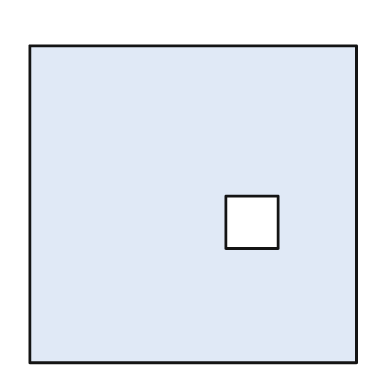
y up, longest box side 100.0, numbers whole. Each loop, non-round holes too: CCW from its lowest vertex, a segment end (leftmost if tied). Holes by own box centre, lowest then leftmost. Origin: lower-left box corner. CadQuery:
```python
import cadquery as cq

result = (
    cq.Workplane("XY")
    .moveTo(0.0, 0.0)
    .lineTo(100.0, 0.0)
    .lineTo(100.0, 97.0)
    .lineTo(0.0, 97.0)
    .close()
    .moveTo(60.0, 35.0)
    .lineTo(76.0, 35.0)
    .lineTo(76.0, 51.0)
    .lineTo(60.0, 51.0)
    .close()
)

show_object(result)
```